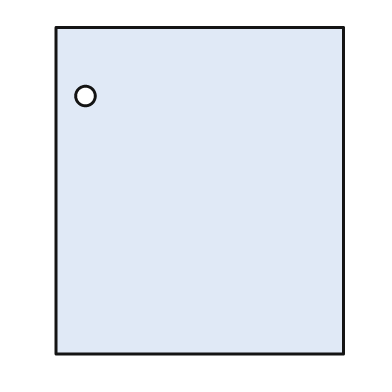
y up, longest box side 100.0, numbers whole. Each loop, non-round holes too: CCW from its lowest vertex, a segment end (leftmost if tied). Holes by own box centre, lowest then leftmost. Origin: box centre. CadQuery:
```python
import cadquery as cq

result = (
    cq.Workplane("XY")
    .moveTo(-44.0, -50.0)
    .lineTo(44.0, -50.0)
    .lineTo(44.0, 50.0)
    .lineTo(-44.0, 50.0)
    .close()
    .moveTo(-35.0, 29.0)
    .circle(3.0)
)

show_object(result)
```